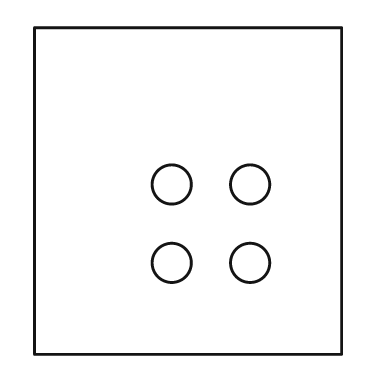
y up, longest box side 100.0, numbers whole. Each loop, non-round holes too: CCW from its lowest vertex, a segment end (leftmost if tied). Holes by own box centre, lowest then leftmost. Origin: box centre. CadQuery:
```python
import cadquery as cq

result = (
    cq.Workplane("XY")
    .moveTo(-47.0, -50.0)
    .lineTo(47.0, -50.0)
    .lineTo(47.0, 50.0)
    .lineTo(-47.0, 50.0)
    .close()
    .moveTo(-5.0, -22.0)
    .circle(6.0)
    .moveTo(19.0, -22.0)
    .circle(6.0)
    .moveTo(-5.0, 2.0)
    .circle(6.0)
    .moveTo(19.0, 2.0)
    .circle(6.0)
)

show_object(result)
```